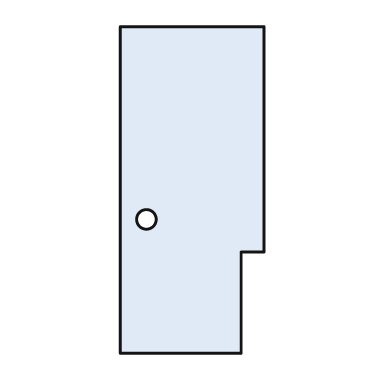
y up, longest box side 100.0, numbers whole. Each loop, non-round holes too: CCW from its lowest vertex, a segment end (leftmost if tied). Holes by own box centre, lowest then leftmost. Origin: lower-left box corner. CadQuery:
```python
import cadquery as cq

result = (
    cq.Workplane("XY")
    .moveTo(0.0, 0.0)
    .lineTo(37.0, 0.0)
    .lineTo(37.0, 31.0)
    .lineTo(44.0, 31.0)
    .lineTo(44.0, 100.0)
    .lineTo(0.0, 100.0)
    .close()
    .moveTo(8.0, 41.0)
    .circle(3.0)
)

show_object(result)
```